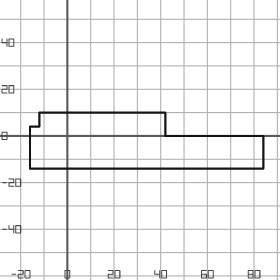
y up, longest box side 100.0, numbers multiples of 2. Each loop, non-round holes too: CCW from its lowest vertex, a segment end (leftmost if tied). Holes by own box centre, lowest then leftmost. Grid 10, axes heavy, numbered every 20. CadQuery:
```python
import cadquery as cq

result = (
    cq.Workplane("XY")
    .moveTo(-16.0, -14.0)
    .lineTo(84.0, -14.0)
    .lineTo(84.0, 0.0)
    .lineTo(42.0, 0.0)
    .lineTo(42.0, 10.0)
    .lineTo(-12.0, 10.0)
    .lineTo(-12.0, 4.0)
    .lineTo(-16.0, 4.0)
    .close()
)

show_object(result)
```